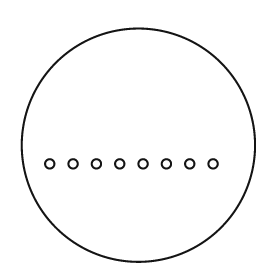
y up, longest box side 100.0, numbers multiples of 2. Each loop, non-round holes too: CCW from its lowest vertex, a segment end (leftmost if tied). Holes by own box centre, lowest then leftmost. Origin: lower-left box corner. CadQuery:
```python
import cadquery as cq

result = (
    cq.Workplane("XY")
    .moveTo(50.0, 50.0)
    .circle(50.0)
    .moveTo(12.0, 42.0)
    .circle(2.0)
    .moveTo(22.0, 42.0)
    .circle(2.0)
    .moveTo(32.0, 42.0)
    .circle(2.0)
    .moveTo(42.0, 42.0)
    .circle(2.0)
    .moveTo(52.0, 42.0)
    .circle(2.0)
    .moveTo(62.0, 42.0)
    .circle(2.0)
    .moveTo(72.0, 42.0)
    .circle(2.0)
    .moveTo(82.0, 42.0)
    .circle(2.0)
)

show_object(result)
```